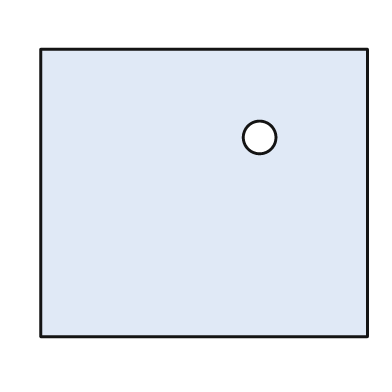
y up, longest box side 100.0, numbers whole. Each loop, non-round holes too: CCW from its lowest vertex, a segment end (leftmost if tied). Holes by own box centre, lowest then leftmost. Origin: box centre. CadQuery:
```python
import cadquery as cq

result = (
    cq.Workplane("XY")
    .moveTo(-50.0, -44.0)
    .lineTo(50.0, -44.0)
    .lineTo(50.0, 44.0)
    .lineTo(-50.0, 44.0)
    .close()
    .moveTo(17.0, 17.0)
    .circle(5.0)
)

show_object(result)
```